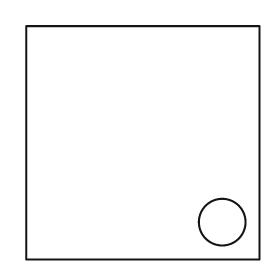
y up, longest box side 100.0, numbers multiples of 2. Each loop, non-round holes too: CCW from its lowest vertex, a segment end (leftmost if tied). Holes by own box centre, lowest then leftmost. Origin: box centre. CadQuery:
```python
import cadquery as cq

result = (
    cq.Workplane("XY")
    .moveTo(-50.0, -50.0)
    .lineTo(50.0, -50.0)
    .lineTo(50.0, 50.0)
    .lineTo(-50.0, 50.0)
    .close()
    .moveTo(34.0, -34.0)
    .circle(10.0)
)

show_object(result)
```